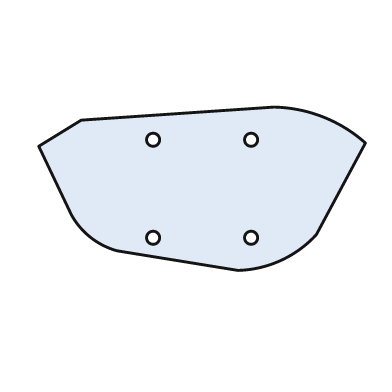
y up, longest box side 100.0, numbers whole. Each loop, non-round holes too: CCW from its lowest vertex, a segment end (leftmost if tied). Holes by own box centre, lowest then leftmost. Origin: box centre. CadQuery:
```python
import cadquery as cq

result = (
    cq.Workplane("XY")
    .moveTo(11.0, -25.0)
    .threePointArc((24.0, -22.0), (35.0, -14.0))
    .lineTo(50.0, 14.0)
    .threePointArc((37.0, 22.0), (22.0, 25.0))
    .lineTo(-37.0, 21.0)
    .lineTo(-50.0, 13.0)
    .lineTo(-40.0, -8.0)
    .threePointArc((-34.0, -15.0), (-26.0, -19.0))
    .close()
    .moveTo(-15.0, -15.0)
    .circle(2.0)
    .moveTo(15.0, -15.0)
    .circle(2.0)
    .moveTo(-15.0, 15.0)
    .circle(2.0)
    .moveTo(15.0, 15.0)
    .circle(2.0)
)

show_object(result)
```